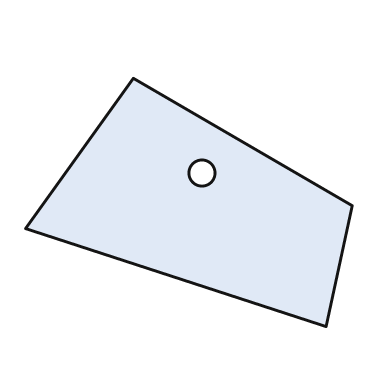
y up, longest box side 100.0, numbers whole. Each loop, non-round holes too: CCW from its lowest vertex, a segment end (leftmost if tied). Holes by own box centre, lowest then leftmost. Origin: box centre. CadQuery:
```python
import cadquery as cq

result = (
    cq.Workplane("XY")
    .moveTo(42.0, -38.0)
    .lineTo(50.0, -1.0)
    .lineTo(-17.0, 38.0)
    .lineTo(-50.0, -8.0)
    .close()
    .moveTo(4.0, 9.0)
    .circle(4.0)
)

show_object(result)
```